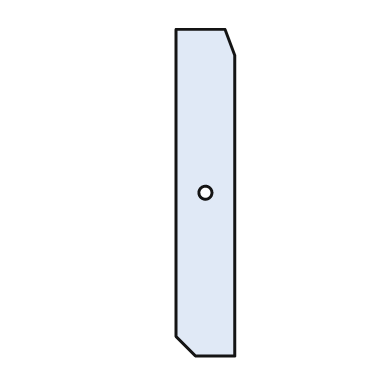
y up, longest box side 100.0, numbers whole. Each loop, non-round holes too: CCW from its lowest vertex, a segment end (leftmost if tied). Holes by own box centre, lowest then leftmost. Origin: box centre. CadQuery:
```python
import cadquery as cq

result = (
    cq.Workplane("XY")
    .moveTo(-3.0, -50.0)
    .lineTo(9.0, -50.0)
    .lineTo(9.0, 42.0)
    .lineTo(6.0, 50.0)
    .lineTo(-9.0, 50.0)
    .lineTo(-9.0, -44.0)
    .close()
    .moveTo(0.0, 0.0)
    .circle(2.0)
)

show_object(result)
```